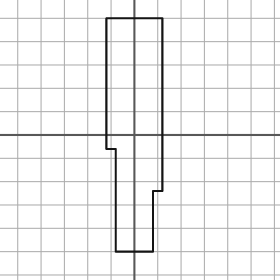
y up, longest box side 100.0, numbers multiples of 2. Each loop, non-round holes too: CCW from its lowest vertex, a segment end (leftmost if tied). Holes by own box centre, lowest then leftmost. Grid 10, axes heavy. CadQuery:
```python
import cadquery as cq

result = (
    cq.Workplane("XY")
    .moveTo(-8.0, -50.0)
    .lineTo(8.0, -50.0)
    .lineTo(8.0, -24.0)
    .lineTo(12.0, -24.0)
    .lineTo(12.0, 50.0)
    .lineTo(-12.0, 50.0)
    .lineTo(-12.0, -6.0)
    .lineTo(-8.0, -6.0)
    .close()
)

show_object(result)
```